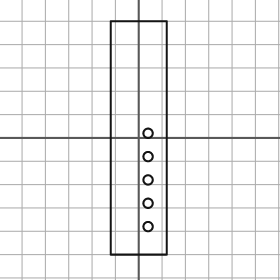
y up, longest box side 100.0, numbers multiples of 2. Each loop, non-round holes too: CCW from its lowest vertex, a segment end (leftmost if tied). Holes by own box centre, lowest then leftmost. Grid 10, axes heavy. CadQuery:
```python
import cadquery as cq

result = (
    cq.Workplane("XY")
    .moveTo(-12.0, -50.0)
    .lineTo(12.0, -50.0)
    .lineTo(12.0, 50.0)
    .lineTo(-12.0, 50.0)
    .close()
    .moveTo(4.0, -38.0)
    .circle(2.0)
    .moveTo(4.0, -28.0)
    .circle(2.0)
    .moveTo(4.0, -18.0)
    .circle(2.0)
    .moveTo(4.0, -8.0)
    .circle(2.0)
    .moveTo(4.0, 2.0)
    .circle(2.0)
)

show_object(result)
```